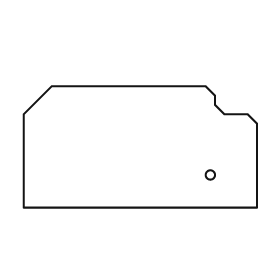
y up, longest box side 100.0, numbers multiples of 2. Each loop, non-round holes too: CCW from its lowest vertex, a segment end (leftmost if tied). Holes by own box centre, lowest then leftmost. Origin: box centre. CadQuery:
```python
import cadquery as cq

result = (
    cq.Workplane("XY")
    .moveTo(-50.0, -26.0)
    .lineTo(50.0, -26.0)
    .lineTo(50.0, 10.0)
    .lineTo(46.0, 14.0)
    .lineTo(36.0, 14.0)
    .lineTo(32.0, 18.0)
    .lineTo(32.0, 22.0)
    .lineTo(28.0, 26.0)
    .lineTo(-38.0, 26.0)
    .lineTo(-50.0, 14.0)
    .close()
    .moveTo(30.0, -12.0)
    .circle(2.0)
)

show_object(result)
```